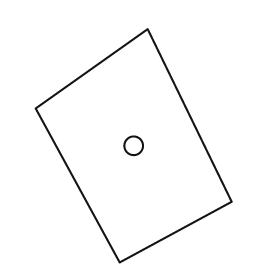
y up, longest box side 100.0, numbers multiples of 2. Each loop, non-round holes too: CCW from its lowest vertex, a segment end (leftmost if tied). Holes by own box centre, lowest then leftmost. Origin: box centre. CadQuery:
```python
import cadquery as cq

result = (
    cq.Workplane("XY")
    .moveTo(-6.0, -50.0)
    .lineTo(42.0, -24.0)
    .lineTo(6.0, 50.0)
    .lineTo(-42.0, 16.0)
    .close()
    .moveTo(0.0, 0.0)
    .circle(4.0)
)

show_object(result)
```